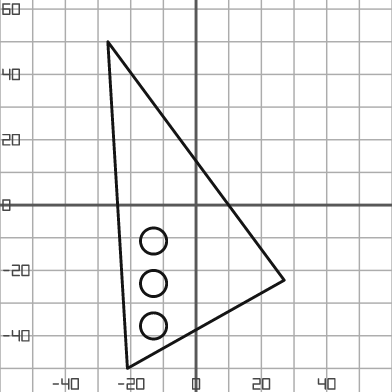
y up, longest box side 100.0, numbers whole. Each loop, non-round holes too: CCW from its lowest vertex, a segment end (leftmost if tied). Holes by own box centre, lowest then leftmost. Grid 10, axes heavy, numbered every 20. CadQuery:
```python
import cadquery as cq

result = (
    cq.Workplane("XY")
    .moveTo(-21.0, -50.0)
    .lineTo(27.0, -23.0)
    .lineTo(-27.0, 50.0)
    .close()
    .moveTo(-13.0, -37.0)
    .circle(4.0)
    .moveTo(-13.0, -24.0)
    .circle(4.0)
    .moveTo(-13.0, -11.0)
    .circle(4.0)
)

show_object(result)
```